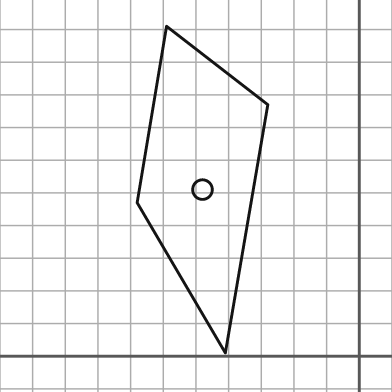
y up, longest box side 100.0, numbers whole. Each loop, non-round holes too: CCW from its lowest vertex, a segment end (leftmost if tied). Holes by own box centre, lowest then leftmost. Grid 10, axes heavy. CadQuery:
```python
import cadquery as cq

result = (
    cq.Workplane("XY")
    .moveTo(-41.0, 1.0)
    .lineTo(-28.0, 77.0)
    .lineTo(-59.0, 101.0)
    .lineTo(-68.0, 47.0)
    .close()
    .moveTo(-48.0, 51.0)
    .circle(3.0)
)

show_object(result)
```